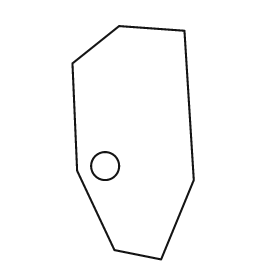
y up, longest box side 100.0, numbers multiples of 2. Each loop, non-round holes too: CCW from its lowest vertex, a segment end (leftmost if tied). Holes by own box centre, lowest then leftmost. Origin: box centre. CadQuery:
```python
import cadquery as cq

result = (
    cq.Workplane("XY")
    .moveTo(12.0, -50.0)
    .lineTo(26.0, -16.0)
    .lineTo(22.0, 48.0)
    .lineTo(-6.0, 50.0)
    .lineTo(-26.0, 34.0)
    .lineTo(-24.0, -12.0)
    .lineTo(-8.0, -46.0)
    .close()
    .moveTo(-12.0, -10.0)
    .circle(6.0)
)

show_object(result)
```